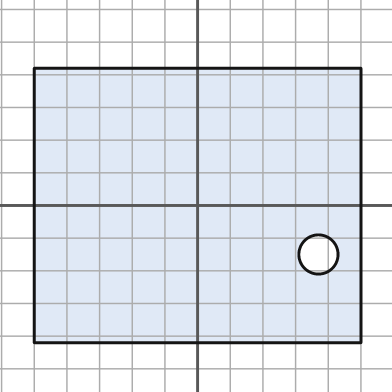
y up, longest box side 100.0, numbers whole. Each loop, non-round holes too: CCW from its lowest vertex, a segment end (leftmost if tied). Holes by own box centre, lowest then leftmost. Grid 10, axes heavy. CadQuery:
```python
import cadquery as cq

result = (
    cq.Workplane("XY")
    .moveTo(-50.0, -42.0)
    .lineTo(50.0, -42.0)
    .lineTo(50.0, 42.0)
    .lineTo(-50.0, 42.0)
    .close()
    .moveTo(37.0, -15.0)
    .circle(6.0)
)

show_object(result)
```